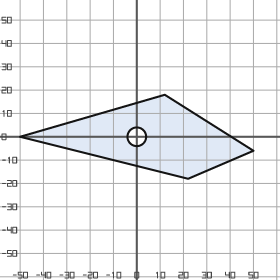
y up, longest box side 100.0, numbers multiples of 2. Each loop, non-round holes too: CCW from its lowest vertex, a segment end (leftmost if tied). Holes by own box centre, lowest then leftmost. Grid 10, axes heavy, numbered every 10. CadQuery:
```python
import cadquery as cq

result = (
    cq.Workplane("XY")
    .moveTo(22.0, -18.0)
    .lineTo(50.0, -6.0)
    .lineTo(12.0, 18.0)
    .lineTo(-50.0, 0.0)
    .close()
    .moveTo(0.0, 0.0)
    .circle(4.0)
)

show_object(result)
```